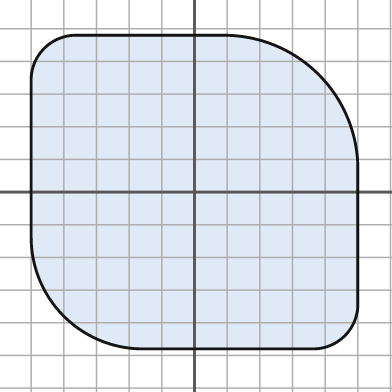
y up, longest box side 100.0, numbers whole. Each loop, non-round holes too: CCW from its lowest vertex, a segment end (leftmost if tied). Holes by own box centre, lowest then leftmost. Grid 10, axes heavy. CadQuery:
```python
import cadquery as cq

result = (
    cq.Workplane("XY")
    .moveTo(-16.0, -48.0)
    .lineTo(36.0, -48.0)
    .threePointArc((46.0, -44.0), (50.0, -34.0))
    .lineTo(50.0, 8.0)
    .threePointArc((38.0, 36.0), (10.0, 48.0))
    .lineTo(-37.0, 48.0)
    .threePointArc((-46.0, 44.0), (-50.0, 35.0))
    .lineTo(-50.0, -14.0)
    .threePointArc((-40.0, -38.0), (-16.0, -48.0))
    .close()
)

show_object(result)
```